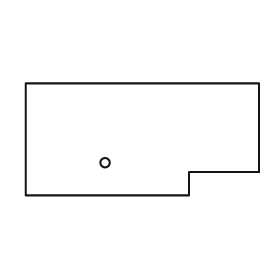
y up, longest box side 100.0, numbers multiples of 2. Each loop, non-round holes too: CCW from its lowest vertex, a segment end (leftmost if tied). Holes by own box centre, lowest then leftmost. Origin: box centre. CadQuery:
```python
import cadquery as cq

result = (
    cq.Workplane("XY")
    .moveTo(-50.0, -24.0)
    .lineTo(20.0, -24.0)
    .lineTo(20.0, -14.0)
    .lineTo(50.0, -14.0)
    .lineTo(50.0, 24.0)
    .lineTo(-50.0, 24.0)
    .close()
    .moveTo(-16.0, -10.0)
    .circle(2.0)
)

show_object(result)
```